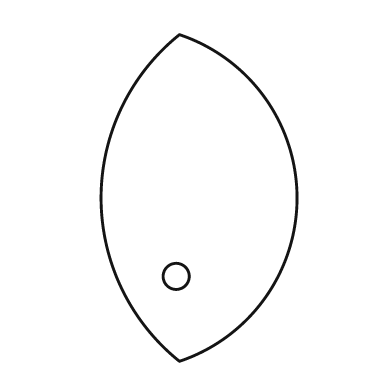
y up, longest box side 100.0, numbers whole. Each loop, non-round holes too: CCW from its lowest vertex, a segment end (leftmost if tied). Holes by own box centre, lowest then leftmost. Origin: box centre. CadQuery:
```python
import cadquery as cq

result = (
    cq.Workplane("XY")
    .moveTo(-6.0, -50.0)
    .threePointArc((30.0, 0.0), (-6.0, 50.0))
    .threePointArc((-30.0, 0.0), (-6.0, -50.0))
    .close()
    .moveTo(-7.0, -24.0)
    .circle(4.0)
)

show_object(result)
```